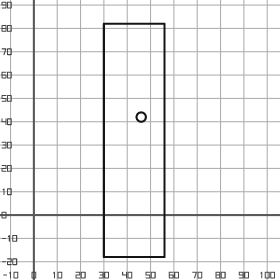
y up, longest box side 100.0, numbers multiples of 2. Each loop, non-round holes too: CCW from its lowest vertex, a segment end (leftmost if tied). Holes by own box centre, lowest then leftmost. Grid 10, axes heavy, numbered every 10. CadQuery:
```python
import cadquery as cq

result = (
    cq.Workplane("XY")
    .moveTo(30.0, -18.0)
    .lineTo(56.0, -18.0)
    .lineTo(56.0, 82.0)
    .lineTo(30.0, 82.0)
    .close()
    .moveTo(46.0, 42.0)
    .circle(2.0)
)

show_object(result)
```